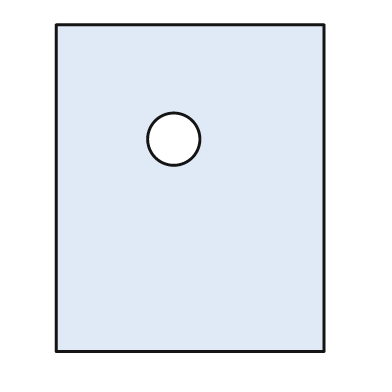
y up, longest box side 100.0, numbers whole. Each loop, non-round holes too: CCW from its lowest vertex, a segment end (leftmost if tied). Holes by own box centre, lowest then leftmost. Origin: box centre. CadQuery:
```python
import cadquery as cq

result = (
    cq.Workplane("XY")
    .moveTo(-41.0, -50.0)
    .lineTo(41.0, -50.0)
    .lineTo(41.0, 50.0)
    .lineTo(-41.0, 50.0)
    .close()
    .moveTo(-5.0, 15.0)
    .circle(8.0)
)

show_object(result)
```